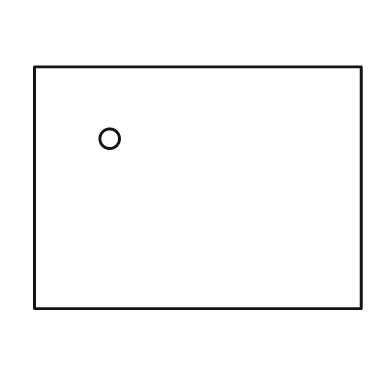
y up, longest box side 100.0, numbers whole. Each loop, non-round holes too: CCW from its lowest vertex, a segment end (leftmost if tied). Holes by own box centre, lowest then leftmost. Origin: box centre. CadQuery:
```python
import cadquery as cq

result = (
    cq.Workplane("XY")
    .moveTo(-50.0, -37.0)
    .lineTo(50.0, -37.0)
    .lineTo(50.0, 37.0)
    .lineTo(-50.0, 37.0)
    .close()
    .moveTo(-27.0, 15.0)
    .circle(3.0)
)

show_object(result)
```